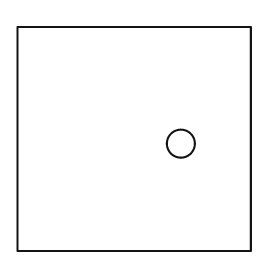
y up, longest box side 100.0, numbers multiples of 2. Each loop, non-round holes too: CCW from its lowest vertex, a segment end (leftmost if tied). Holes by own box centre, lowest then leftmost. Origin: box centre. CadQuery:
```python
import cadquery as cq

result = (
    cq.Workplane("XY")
    .moveTo(-50.0, -48.0)
    .lineTo(50.0, -48.0)
    .lineTo(50.0, 48.0)
    .lineTo(-50.0, 48.0)
    .close()
    .moveTo(20.0, -2.0)
    .circle(6.0)
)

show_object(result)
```